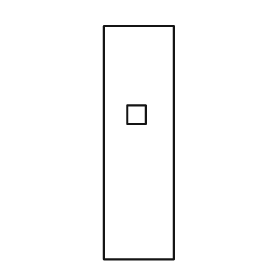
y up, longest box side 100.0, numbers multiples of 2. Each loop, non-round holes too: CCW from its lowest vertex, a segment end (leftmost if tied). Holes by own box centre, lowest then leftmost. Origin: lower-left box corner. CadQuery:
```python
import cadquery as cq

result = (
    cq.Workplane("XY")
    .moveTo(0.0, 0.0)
    .lineTo(30.0, 0.0)
    .lineTo(30.0, 100.0)
    .lineTo(0.0, 100.0)
    .close()
    .moveTo(10.0, 58.0)
    .lineTo(18.0, 58.0)
    .lineTo(18.0, 66.0)
    .lineTo(10.0, 66.0)
    .close()
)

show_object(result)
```